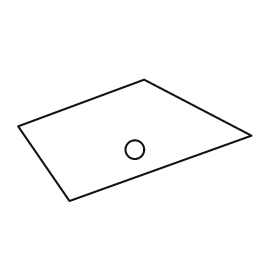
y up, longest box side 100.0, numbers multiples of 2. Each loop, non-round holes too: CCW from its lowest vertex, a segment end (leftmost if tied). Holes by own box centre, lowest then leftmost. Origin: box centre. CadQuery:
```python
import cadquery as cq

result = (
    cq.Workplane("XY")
    .moveTo(-28.0, -26.0)
    .lineTo(50.0, 2.0)
    .lineTo(4.0, 26.0)
    .lineTo(-50.0, 6.0)
    .close()
    .moveTo(0.0, -4.0)
    .circle(4.0)
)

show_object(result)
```